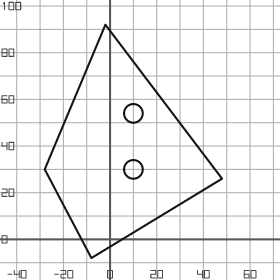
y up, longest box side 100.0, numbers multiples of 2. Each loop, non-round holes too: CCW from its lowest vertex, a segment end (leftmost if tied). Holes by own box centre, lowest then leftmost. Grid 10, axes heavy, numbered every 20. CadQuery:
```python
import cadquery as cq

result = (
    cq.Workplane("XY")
    .moveTo(-8.0, -8.0)
    .lineTo(48.0, 26.0)
    .lineTo(-2.0, 92.0)
    .lineTo(-28.0, 30.0)
    .close()
    .moveTo(10.0, 30.0)
    .circle(4.0)
    .moveTo(10.0, 54.0)
    .circle(4.0)
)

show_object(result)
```